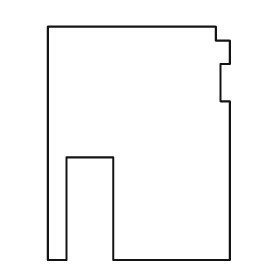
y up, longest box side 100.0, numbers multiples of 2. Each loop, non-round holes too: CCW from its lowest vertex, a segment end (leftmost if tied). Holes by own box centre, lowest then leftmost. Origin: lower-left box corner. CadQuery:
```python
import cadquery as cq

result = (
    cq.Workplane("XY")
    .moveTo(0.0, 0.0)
    .lineTo(8.0, 0.0)
    .lineTo(8.0, 44.0)
    .lineTo(28.0, 44.0)
    .lineTo(28.0, 0.0)
    .lineTo(78.0, 0.0)
    .lineTo(78.0, 68.0)
    .lineTo(74.0, 68.0)
    .lineTo(74.0, 84.0)
    .lineTo(78.0, 84.0)
    .lineTo(78.0, 94.0)
    .lineTo(72.0, 94.0)
    .lineTo(72.0, 100.0)
    .lineTo(0.0, 100.0)
    .close()
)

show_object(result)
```